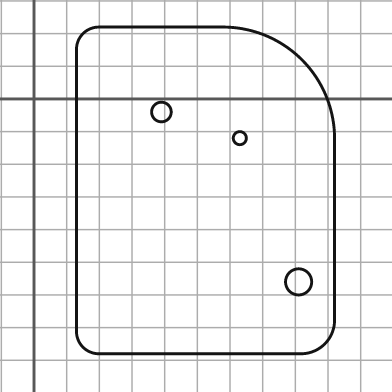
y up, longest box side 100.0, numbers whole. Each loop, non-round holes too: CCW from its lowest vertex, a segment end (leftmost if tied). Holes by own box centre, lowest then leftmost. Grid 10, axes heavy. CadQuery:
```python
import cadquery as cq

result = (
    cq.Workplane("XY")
    .moveTo(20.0, -78.0)
    .lineTo(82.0, -78.0)
    .threePointArc((89.0, -75.0), (92.0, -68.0))
    .lineTo(92.0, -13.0)
    .threePointArc((82.0, 12.0), (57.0, 22.0))
    .lineTo(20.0, 22.0)
    .threePointArc((15.0, 20.0), (13.0, 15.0))
    .lineTo(13.0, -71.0)
    .threePointArc((15.0, -76.0), (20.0, -78.0))
    .close()
    .moveTo(81.0, -56.0)
    .circle(4.0)
    .moveTo(63.0, -12.0)
    .circle(2.0)
    .moveTo(39.0, -4.0)
    .circle(3.0)
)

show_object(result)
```